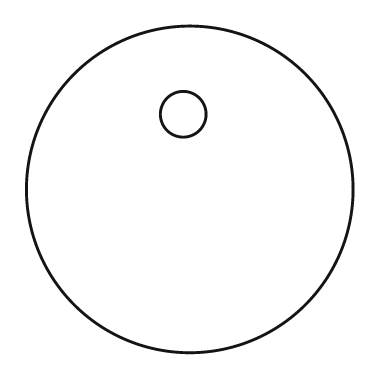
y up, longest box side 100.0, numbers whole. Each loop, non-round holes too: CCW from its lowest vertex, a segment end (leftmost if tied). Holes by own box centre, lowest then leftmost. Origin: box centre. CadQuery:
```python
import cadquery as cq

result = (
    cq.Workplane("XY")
    .moveTo(0.0, 0.0)
    .circle(50.0)
    .moveTo(-2.0, 23.0)
    .circle(7.0)
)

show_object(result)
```